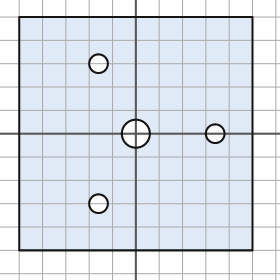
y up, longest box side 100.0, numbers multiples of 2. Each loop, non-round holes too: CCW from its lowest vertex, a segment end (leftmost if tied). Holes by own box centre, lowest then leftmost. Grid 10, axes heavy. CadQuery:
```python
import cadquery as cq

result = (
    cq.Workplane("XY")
    .moveTo(-50.0, -50.0)
    .lineTo(50.0, -50.0)
    .lineTo(50.0, 50.0)
    .lineTo(-50.0, 50.0)
    .close()
    .moveTo(-16.0, -30.0)
    .circle(4.0)
    .moveTo(0.0, 0.0)
    .circle(6.0)
    .moveTo(34.0, 0.0)
    .circle(4.0)
    .moveTo(-16.0, 30.0)
    .circle(4.0)
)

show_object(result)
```